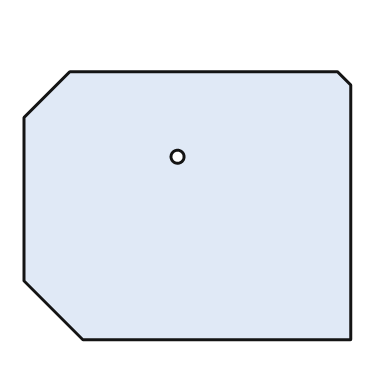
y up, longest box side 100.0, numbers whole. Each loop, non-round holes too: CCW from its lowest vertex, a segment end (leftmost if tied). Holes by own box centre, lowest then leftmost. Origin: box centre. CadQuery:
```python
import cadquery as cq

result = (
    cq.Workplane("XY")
    .moveTo(-32.0, -41.0)
    .lineTo(50.0, -41.0)
    .lineTo(50.0, 37.0)
    .lineTo(46.0, 41.0)
    .lineTo(-36.0, 41.0)
    .lineTo(-50.0, 27.0)
    .lineTo(-50.0, -23.0)
    .close()
    .moveTo(-3.0, 15.0)
    .circle(2.0)
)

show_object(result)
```